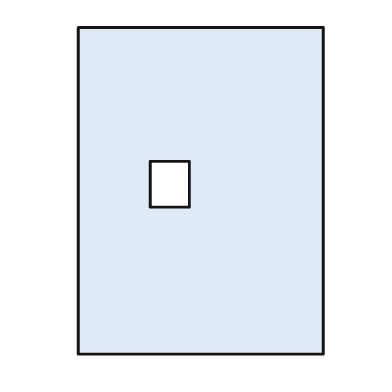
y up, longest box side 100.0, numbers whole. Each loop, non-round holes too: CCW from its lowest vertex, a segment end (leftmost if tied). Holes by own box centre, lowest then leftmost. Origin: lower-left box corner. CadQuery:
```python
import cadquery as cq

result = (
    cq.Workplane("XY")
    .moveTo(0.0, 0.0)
    .lineTo(75.0, 0.0)
    .lineTo(75.0, 100.0)
    .lineTo(0.0, 100.0)
    .close()
    .moveTo(22.0, 45.0)
    .lineTo(34.0, 45.0)
    .lineTo(34.0, 59.0)
    .lineTo(22.0, 59.0)
    .close()
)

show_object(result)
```